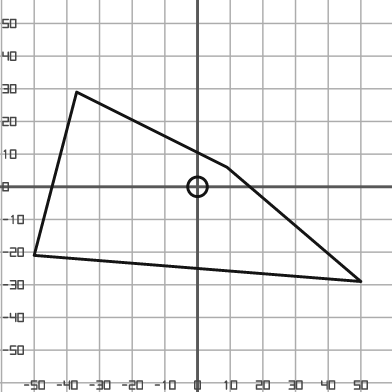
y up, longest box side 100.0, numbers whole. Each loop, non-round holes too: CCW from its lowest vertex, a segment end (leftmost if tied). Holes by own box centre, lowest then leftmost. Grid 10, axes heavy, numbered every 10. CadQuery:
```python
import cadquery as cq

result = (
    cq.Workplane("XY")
    .moveTo(50.0, -29.0)
    .lineTo(9.0, 6.0)
    .lineTo(-37.0, 29.0)
    .lineTo(-50.0, -21.0)
    .close()
    .moveTo(0.0, 0.0)
    .circle(3.0)
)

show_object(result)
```